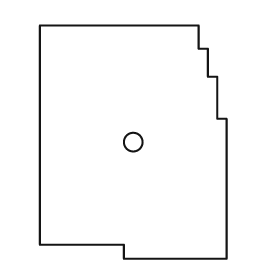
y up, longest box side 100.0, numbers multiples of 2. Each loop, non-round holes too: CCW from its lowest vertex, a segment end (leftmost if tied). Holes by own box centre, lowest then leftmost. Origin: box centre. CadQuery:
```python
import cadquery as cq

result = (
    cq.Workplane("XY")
    .moveTo(-4.0, -50.0)
    .lineTo(40.0, -50.0)
    .lineTo(40.0, 10.0)
    .lineTo(36.0, 10.0)
    .lineTo(36.0, 28.0)
    .lineTo(32.0, 28.0)
    .lineTo(32.0, 40.0)
    .lineTo(28.0, 40.0)
    .lineTo(28.0, 50.0)
    .lineTo(-40.0, 50.0)
    .lineTo(-40.0, -44.0)
    .lineTo(-4.0, -44.0)
    .close()
    .moveTo(0.0, 0.0)
    .circle(4.0)
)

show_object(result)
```